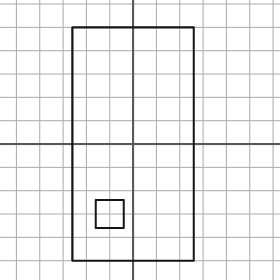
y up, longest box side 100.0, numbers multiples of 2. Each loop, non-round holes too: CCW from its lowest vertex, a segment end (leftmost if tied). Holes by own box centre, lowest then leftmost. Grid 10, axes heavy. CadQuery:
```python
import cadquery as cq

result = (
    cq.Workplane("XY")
    .moveTo(-26.0, -50.0)
    .lineTo(26.0, -50.0)
    .lineTo(26.0, 50.0)
    .lineTo(-26.0, 50.0)
    .close()
    .moveTo(-16.0, -36.0)
    .lineTo(-4.0, -36.0)
    .lineTo(-4.0, -24.0)
    .lineTo(-16.0, -24.0)
    .close()
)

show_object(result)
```